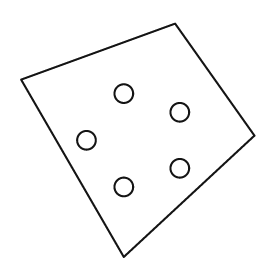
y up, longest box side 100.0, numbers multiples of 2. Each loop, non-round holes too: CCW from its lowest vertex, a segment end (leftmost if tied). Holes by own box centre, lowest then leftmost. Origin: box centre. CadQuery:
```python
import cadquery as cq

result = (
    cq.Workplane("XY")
    .moveTo(-6.0, -50.0)
    .lineTo(50.0, 2.0)
    .lineTo(16.0, 50.0)
    .lineTo(-50.0, 26.0)
    .close()
    .moveTo(-6.0, -20.0)
    .circle(4.0)
    .moveTo(18.0, -12.0)
    .circle(4.0)
    .moveTo(-22.0, 0.0)
    .circle(4.0)
    .moveTo(18.0, 12.0)
    .circle(4.0)
    .moveTo(-6.0, 20.0)
    .circle(4.0)
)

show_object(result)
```